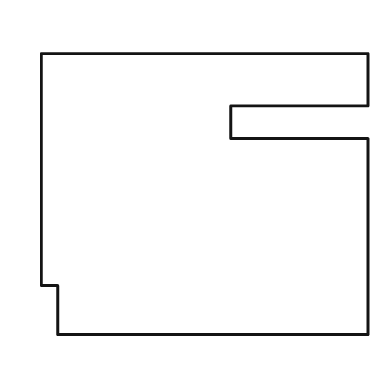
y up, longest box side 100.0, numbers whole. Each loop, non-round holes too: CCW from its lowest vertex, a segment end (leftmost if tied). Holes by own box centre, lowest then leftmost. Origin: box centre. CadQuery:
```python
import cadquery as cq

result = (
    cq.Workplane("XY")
    .moveTo(-45.0, -43.0)
    .lineTo(50.0, -43.0)
    .lineTo(50.0, 17.0)
    .lineTo(8.0, 17.0)
    .lineTo(8.0, 27.0)
    .lineTo(50.0, 27.0)
    .lineTo(50.0, 43.0)
    .lineTo(-50.0, 43.0)
    .lineTo(-50.0, -28.0)
    .lineTo(-45.0, -28.0)
    .close()
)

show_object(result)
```